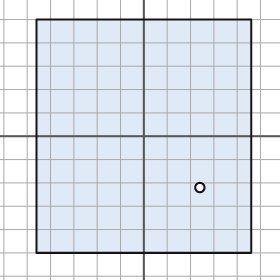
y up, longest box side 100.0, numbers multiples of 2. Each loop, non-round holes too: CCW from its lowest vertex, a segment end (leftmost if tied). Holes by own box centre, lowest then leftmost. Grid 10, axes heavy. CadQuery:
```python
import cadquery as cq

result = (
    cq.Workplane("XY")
    .moveTo(-46.0, -50.0)
    .lineTo(46.0, -50.0)
    .lineTo(46.0, 50.0)
    .lineTo(-46.0, 50.0)
    .close()
    .moveTo(24.0, -22.0)
    .circle(2.0)
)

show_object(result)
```